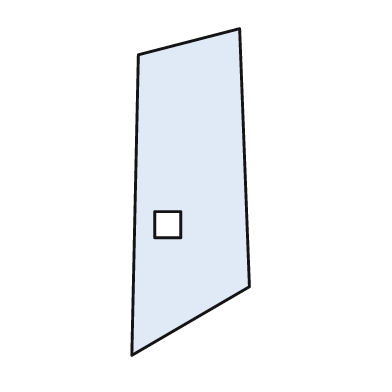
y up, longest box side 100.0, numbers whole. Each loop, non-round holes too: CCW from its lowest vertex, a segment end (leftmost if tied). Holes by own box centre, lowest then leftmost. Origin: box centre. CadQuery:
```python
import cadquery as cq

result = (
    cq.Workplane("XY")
    .moveTo(-18.0, -50.0)
    .lineTo(18.0, -29.0)
    .lineTo(15.0, 50.0)
    .lineTo(-16.0, 42.0)
    .close()
    .moveTo(-11.0, -14.0)
    .lineTo(-3.0, -14.0)
    .lineTo(-3.0, -6.0)
    .lineTo(-11.0, -6.0)
    .close()
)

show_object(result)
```